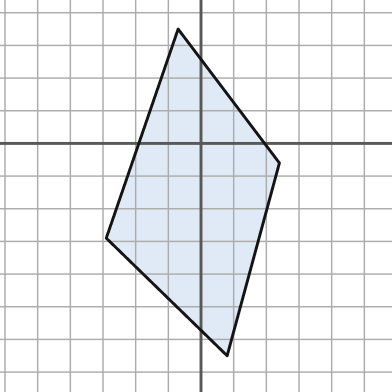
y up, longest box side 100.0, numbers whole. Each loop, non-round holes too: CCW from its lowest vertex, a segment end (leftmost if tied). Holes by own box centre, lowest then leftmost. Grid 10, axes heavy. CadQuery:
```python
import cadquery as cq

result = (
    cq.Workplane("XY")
    .moveTo(8.0, -65.0)
    .lineTo(24.0, -6.0)
    .lineTo(-7.0, 35.0)
    .lineTo(-29.0, -29.0)
    .close()
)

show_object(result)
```